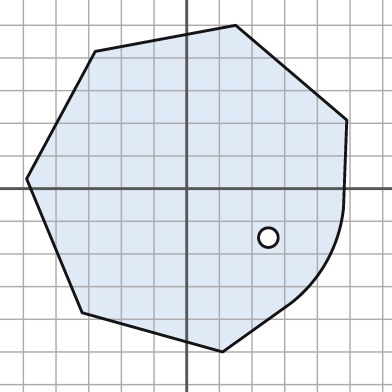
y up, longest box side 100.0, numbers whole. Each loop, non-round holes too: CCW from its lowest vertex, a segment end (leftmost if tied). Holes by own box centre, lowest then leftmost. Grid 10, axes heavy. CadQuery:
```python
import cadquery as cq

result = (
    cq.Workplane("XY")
    .moveTo(11.0, -50.0)
    .lineTo(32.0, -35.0)
    .threePointArc((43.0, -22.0), (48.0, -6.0))
    .lineTo(49.0, 21.0)
    .lineTo(15.0, 50.0)
    .lineTo(-28.0, 42.0)
    .lineTo(-49.0, 3.0)
    .lineTo(-32.0, -38.0)
    .close()
    .moveTo(25.0, -15.0)
    .circle(3.0)
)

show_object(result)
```